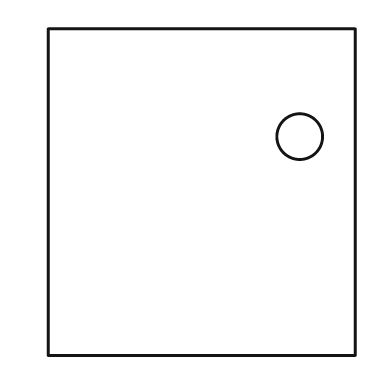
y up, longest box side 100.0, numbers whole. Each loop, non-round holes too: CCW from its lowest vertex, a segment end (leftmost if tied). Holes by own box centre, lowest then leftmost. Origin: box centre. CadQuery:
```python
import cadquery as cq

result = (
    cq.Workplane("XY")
    .moveTo(-47.0, -50.0)
    .lineTo(47.0, -50.0)
    .lineTo(47.0, 50.0)
    .lineTo(-47.0, 50.0)
    .close()
    .moveTo(30.0, 17.0)
    .circle(7.0)
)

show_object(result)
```